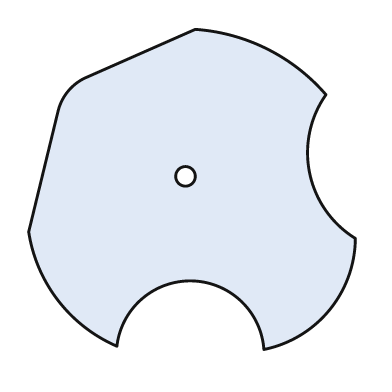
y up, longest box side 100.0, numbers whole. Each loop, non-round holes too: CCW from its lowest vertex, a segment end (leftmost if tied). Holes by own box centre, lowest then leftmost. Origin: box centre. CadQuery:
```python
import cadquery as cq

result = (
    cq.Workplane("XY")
    .moveTo(22.0, -49.0)
    .threePointArc((42.0, -37.0), (50.0, -15.0))
    .threePointArc((36.0, 5.0), (41.0, 29.0))
    .threePointArc((23.0, 43.0), (1.0, 49.0))
    .lineTo(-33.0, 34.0)
    .threePointArc((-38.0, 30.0), (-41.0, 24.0))
    .lineTo(-50.0, -13.0)
    .threePointArc((-41.0, -34.0), (-23.0, -48.0))
    .threePointArc((0.0, -28.0), (22.0, -49.0))
    .close()
    .moveTo(-2.0, 4.0)
    .circle(3.0)
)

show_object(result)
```